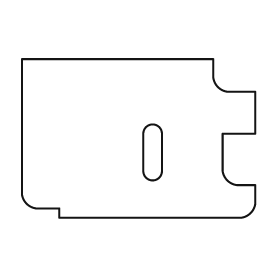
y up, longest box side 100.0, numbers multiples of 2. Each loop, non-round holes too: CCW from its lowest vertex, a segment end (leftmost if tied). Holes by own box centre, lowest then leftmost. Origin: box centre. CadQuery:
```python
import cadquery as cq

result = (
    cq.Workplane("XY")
    .moveTo(-34.0, -34.0)
    .lineTo(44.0, -34.0)
    .threePointArc((48.0, -32.0), (50.0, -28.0))
    .lineTo(50.0, -20.0)
    .lineTo(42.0, -20.0)
    .threePointArc((38.0, -18.0), (36.0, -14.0))
    .lineTo(36.0, 2.0)
    .lineTo(50.0, 2.0)
    .lineTo(50.0, 20.0)
    .lineTo(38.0, 20.0)
    .threePointArc((34.0, 22.0), (32.0, 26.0))
    .lineTo(32.0, 34.0)
    .lineTo(-50.0, 34.0)
    .lineTo(-50.0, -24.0)
    .threePointArc((-48.0, -28.0), (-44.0, -30.0))
    .lineTo(-34.0, -30.0)
    .close()
    .moveTo(2.0, -14.0)
    .threePointArc((6.0, -18.0), (10.0, -14.0))
    .lineTo(10.0, 2.0)
    .threePointArc((6.0, 6.0), (2.0, 2.0))
    .close()
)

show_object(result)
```